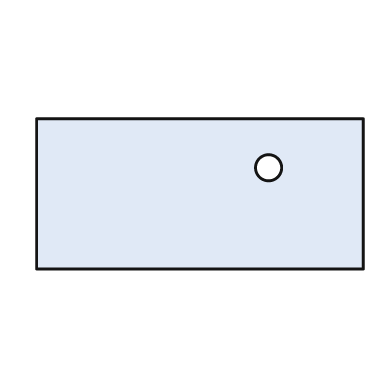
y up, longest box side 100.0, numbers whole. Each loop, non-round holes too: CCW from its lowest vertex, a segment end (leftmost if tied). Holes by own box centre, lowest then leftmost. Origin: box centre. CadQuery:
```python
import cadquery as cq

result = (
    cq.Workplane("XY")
    .moveTo(-50.0, -23.0)
    .lineTo(50.0, -23.0)
    .lineTo(50.0, 23.0)
    .lineTo(-50.0, 23.0)
    .close()
    .moveTo(21.0, 8.0)
    .circle(4.0)
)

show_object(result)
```